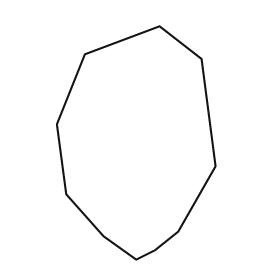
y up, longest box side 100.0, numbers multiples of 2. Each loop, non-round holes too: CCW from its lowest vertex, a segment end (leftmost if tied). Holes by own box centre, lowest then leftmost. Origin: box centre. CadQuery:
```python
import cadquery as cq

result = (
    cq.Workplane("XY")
    .moveTo(0.0, -50.0)
    .lineTo(8.0, -46.0)
    .lineTo(18.0, -38.0)
    .lineTo(34.0, -10.0)
    .lineTo(28.0, 36.0)
    .lineTo(10.0, 50.0)
    .lineTo(-22.0, 38.0)
    .lineTo(-34.0, 8.0)
    .lineTo(-30.0, -22.0)
    .lineTo(-14.0, -40.0)
    .close()
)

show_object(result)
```